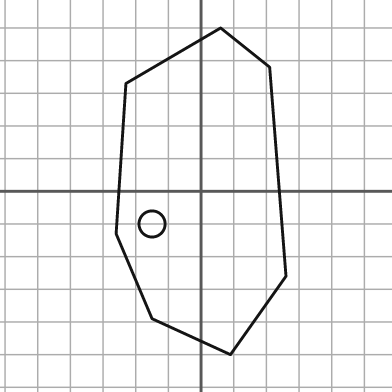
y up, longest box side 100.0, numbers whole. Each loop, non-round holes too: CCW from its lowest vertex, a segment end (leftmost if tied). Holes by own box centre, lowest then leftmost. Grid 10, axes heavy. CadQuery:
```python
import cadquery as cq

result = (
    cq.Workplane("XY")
    .moveTo(9.0, -50.0)
    .lineTo(26.0, -26.0)
    .lineTo(21.0, 38.0)
    .lineTo(6.0, 50.0)
    .lineTo(-23.0, 33.0)
    .lineTo(-26.0, -13.0)
    .lineTo(-15.0, -39.0)
    .close()
    .moveTo(-15.0, -10.0)
    .circle(4.0)
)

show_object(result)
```